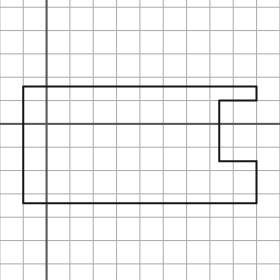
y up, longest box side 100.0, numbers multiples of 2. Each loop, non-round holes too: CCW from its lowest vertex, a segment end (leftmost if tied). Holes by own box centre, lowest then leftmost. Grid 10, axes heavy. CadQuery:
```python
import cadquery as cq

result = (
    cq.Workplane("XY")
    .moveTo(-10.0, -34.0)
    .lineTo(90.0, -34.0)
    .lineTo(90.0, -16.0)
    .lineTo(74.0, -16.0)
    .lineTo(74.0, 10.0)
    .lineTo(90.0, 10.0)
    .lineTo(90.0, 16.0)
    .lineTo(-10.0, 16.0)
    .close()
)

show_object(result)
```